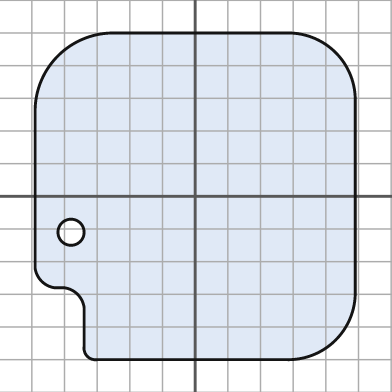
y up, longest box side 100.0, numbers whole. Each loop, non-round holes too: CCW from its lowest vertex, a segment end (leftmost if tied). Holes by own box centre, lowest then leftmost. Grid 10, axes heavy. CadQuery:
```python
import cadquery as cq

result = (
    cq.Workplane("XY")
    .moveTo(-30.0, -50.0)
    .lineTo(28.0, -50.0)
    .threePointArc((43.0, -44.0), (49.0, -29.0))
    .lineTo(49.0, 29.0)
    .threePointArc((43.0, 44.0), (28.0, 50.0))
    .lineTo(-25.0, 50.0)
    .threePointArc((-42.0, 43.0), (-49.0, 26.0))
    .lineTo(-49.0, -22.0)
    .threePointArc((-47.0, -26.0), (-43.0, -28.0))
    .lineTo(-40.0, -28.0)
    .threePointArc((-36.0, -30.0), (-34.0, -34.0))
    .lineTo(-34.0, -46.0)
    .threePointArc((-33.0, -49.0), (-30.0, -50.0))
    .close()
    .moveTo(-38.0, -11.0)
    .circle(4.0)
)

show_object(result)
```